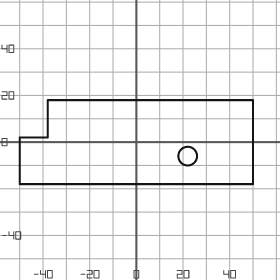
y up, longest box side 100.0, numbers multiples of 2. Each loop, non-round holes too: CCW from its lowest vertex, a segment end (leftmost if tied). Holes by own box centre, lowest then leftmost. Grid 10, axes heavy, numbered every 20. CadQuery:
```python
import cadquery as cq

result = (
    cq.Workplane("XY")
    .moveTo(-50.0, -18.0)
    .lineTo(50.0, -18.0)
    .lineTo(50.0, 18.0)
    .lineTo(-38.0, 18.0)
    .lineTo(-38.0, 2.0)
    .lineTo(-50.0, 2.0)
    .close()
    .moveTo(22.0, -6.0)
    .circle(4.0)
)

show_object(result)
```